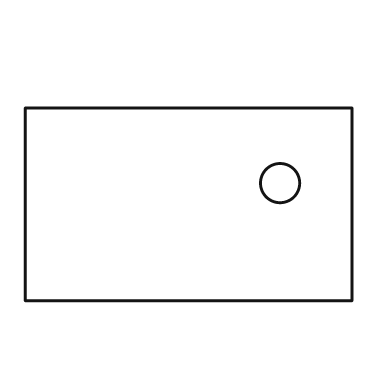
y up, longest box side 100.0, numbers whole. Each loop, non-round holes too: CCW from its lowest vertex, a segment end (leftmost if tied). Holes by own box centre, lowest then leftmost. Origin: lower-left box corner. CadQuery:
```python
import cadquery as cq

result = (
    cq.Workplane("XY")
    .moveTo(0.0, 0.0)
    .lineTo(100.0, 0.0)
    .lineTo(100.0, 59.0)
    .lineTo(0.0, 59.0)
    .close()
    .moveTo(78.0, 36.0)
    .circle(6.0)
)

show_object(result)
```